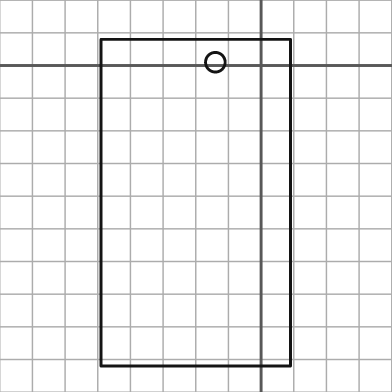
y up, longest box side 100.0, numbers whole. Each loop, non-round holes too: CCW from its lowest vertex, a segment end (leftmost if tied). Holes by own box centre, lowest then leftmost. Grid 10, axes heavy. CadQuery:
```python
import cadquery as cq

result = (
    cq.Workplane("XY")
    .moveTo(-49.0, -92.0)
    .lineTo(9.0, -92.0)
    .lineTo(9.0, 8.0)
    .lineTo(-49.0, 8.0)
    .close()
    .moveTo(-14.0, 1.0)
    .circle(3.0)
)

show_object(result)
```